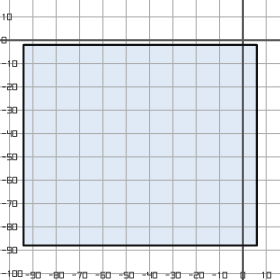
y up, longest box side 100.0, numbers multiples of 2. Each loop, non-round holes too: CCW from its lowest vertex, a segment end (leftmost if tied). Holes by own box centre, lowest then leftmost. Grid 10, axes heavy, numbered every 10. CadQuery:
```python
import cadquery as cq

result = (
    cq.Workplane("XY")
    .moveTo(-94.0, -88.0)
    .lineTo(6.0, -88.0)
    .lineTo(6.0, -2.0)
    .lineTo(-94.0, -2.0)
    .close()
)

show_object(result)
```